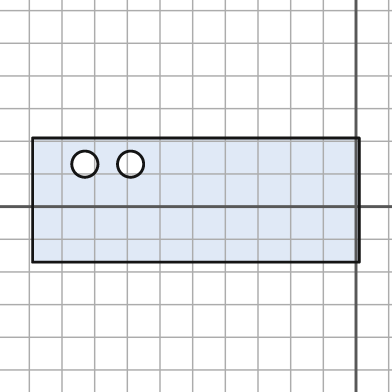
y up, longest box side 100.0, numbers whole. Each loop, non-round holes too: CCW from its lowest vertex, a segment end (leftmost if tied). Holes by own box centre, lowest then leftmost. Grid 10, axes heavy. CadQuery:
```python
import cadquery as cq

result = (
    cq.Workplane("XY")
    .moveTo(-99.0, -17.0)
    .lineTo(1.0, -17.0)
    .lineTo(1.0, 21.0)
    .lineTo(-99.0, 21.0)
    .close()
    .moveTo(-83.0, 13.0)
    .circle(4.0)
    .moveTo(-69.0, 13.0)
    .circle(4.0)
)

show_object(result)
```